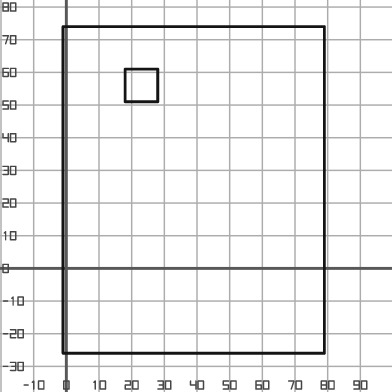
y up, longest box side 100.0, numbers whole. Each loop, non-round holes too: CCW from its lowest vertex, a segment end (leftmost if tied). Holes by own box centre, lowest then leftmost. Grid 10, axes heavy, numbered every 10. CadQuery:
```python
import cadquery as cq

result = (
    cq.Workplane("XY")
    .moveTo(-1.0, -26.0)
    .lineTo(79.0, -26.0)
    .lineTo(79.0, 74.0)
    .lineTo(-1.0, 74.0)
    .close()
    .moveTo(18.0, 51.0)
    .lineTo(28.0, 51.0)
    .lineTo(28.0, 61.0)
    .lineTo(18.0, 61.0)
    .close()
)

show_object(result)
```